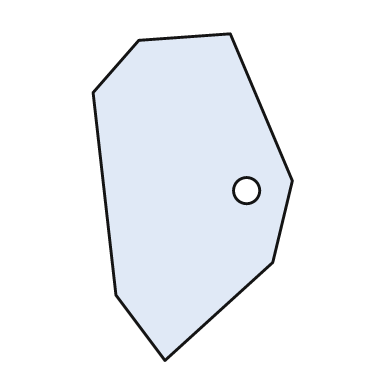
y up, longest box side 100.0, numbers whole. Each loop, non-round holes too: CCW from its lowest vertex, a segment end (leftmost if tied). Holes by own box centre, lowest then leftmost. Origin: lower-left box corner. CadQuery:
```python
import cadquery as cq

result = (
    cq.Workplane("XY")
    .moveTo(22.0, 0.0)
    .lineTo(55.0, 30.0)
    .lineTo(61.0, 55.0)
    .lineTo(42.0, 100.0)
    .lineTo(14.0, 98.0)
    .lineTo(0.0, 82.0)
    .lineTo(7.0, 20.0)
    .close()
    .moveTo(47.0, 52.0)
    .circle(4.0)
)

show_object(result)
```